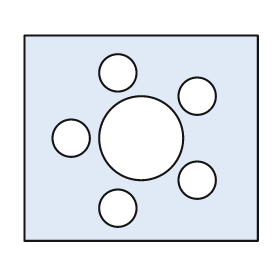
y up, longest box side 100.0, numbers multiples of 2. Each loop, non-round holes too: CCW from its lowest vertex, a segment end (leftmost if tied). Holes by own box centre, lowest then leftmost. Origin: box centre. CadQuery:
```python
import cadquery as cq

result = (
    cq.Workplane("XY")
    .moveTo(-50.0, -44.0)
    .lineTo(50.0, -44.0)
    .lineTo(50.0, 44.0)
    .lineTo(-50.0, 44.0)
    .close()
    .moveTo(-10.0, -30.0)
    .circle(8.0)
    .moveTo(24.0, -18.0)
    .circle(8.0)
    .moveTo(-30.0, 0.0)
    .circle(8.0)
    .moveTo(0.0, 0.0)
    .circle(18.0)
    .moveTo(24.0, 18.0)
    .circle(8.0)
    .moveTo(-10.0, 28.0)
    .circle(8.0)
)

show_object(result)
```